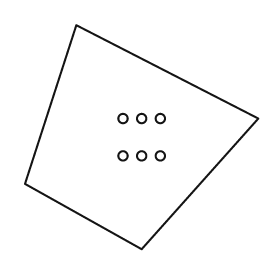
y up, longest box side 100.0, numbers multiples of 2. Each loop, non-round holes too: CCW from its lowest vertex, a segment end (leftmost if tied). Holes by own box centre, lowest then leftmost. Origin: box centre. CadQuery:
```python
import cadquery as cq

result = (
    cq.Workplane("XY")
    .moveTo(0.0, -48.0)
    .lineTo(50.0, 8.0)
    .lineTo(-28.0, 48.0)
    .lineTo(-50.0, -20.0)
    .close()
    .moveTo(-8.0, -8.0)
    .circle(2.0)
    .moveTo(0.0, -8.0)
    .circle(2.0)
    .moveTo(8.0, -8.0)
    .circle(2.0)
    .moveTo(-8.0, 8.0)
    .circle(2.0)
    .moveTo(0.0, 8.0)
    .circle(2.0)
    .moveTo(8.0, 8.0)
    .circle(2.0)
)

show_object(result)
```